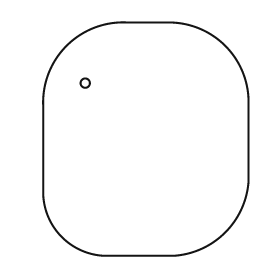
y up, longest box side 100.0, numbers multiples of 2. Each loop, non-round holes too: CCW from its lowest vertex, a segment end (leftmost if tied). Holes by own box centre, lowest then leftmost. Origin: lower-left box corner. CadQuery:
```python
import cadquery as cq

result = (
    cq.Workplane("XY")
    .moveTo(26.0, 0.0)
    .lineTo(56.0, 0.0)
    .threePointArc((78.0, 10.0), (88.0, 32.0))
    .lineTo(88.0, 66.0)
    .threePointArc((78.0, 90.0), (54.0, 100.0))
    .lineTo(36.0, 100.0)
    .threePointArc((10.0, 90.0), (0.0, 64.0))
    .lineTo(0.0, 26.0)
    .threePointArc((8.0, 8.0), (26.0, 0.0))
    .close()
    .moveTo(18.0, 74.0)
    .circle(2.0)
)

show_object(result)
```